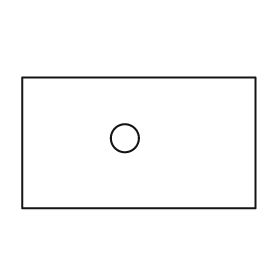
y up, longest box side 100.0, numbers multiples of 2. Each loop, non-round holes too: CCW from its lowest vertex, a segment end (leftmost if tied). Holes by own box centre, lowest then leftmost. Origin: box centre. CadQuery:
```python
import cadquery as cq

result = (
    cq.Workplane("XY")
    .moveTo(-50.0, -28.0)
    .lineTo(50.0, -28.0)
    .lineTo(50.0, 28.0)
    .lineTo(-50.0, 28.0)
    .close()
    .moveTo(-6.0, 2.0)
    .circle(6.0)
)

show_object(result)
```